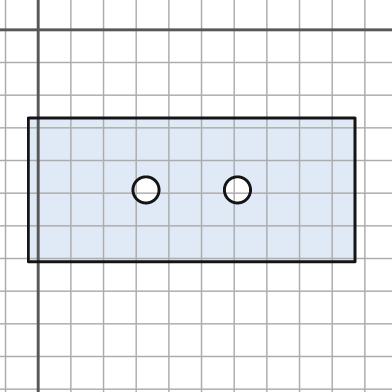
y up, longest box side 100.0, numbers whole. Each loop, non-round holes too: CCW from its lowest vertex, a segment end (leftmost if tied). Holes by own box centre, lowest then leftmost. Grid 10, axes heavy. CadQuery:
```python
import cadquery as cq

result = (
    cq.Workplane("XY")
    .moveTo(-3.0, -71.0)
    .lineTo(97.0, -71.0)
    .lineTo(97.0, -27.0)
    .lineTo(-3.0, -27.0)
    .close()
    .moveTo(33.0, -49.0)
    .circle(4.0)
    .moveTo(61.0, -49.0)
    .circle(4.0)
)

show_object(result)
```